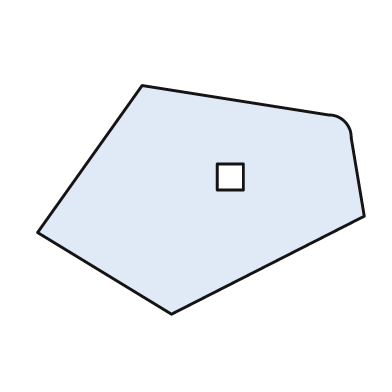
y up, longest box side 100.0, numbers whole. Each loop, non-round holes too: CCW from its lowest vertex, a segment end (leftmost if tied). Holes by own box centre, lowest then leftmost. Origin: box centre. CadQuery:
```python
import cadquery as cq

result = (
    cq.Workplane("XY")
    .moveTo(-9.0, -35.0)
    .lineTo(50.0, -5.0)
    .lineTo(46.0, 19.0)
    .threePointArc((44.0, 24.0), (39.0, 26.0))
    .lineTo(-18.0, 35.0)
    .lineTo(-50.0, -10.0)
    .close()
    .moveTo(5.0, 3.0)
    .lineTo(13.0, 3.0)
    .lineTo(13.0, 11.0)
    .lineTo(5.0, 11.0)
    .close()
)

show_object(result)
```